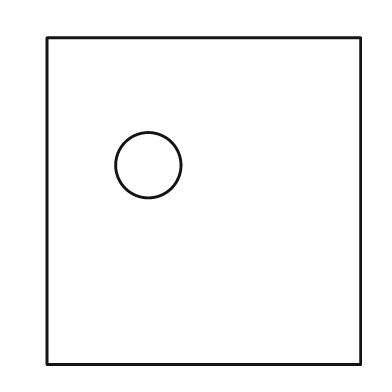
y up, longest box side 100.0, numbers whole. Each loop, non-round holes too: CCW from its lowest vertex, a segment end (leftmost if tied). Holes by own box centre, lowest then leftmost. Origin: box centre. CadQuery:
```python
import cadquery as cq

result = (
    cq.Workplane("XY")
    .moveTo(-48.0, -50.0)
    .lineTo(48.0, -50.0)
    .lineTo(48.0, 50.0)
    .lineTo(-48.0, 50.0)
    .close()
    .moveTo(-17.0, 11.0)
    .circle(10.0)
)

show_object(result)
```